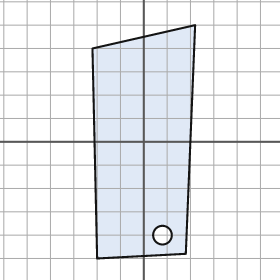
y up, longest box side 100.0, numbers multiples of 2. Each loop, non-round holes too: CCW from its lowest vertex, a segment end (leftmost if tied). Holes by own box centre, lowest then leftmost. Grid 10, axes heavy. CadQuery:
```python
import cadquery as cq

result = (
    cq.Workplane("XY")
    .moveTo(-20.0, -50.0)
    .lineTo(18.0, -48.0)
    .lineTo(22.0, 50.0)
    .lineTo(-22.0, 40.0)
    .close()
    .moveTo(8.0, -40.0)
    .circle(4.0)
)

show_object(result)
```